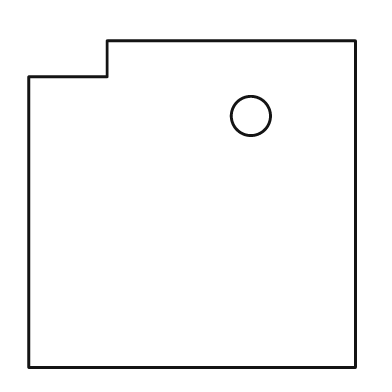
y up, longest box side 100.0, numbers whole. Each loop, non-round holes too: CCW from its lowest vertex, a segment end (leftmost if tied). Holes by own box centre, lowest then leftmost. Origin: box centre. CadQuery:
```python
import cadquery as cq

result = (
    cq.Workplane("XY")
    .moveTo(-50.0, -50.0)
    .lineTo(50.0, -50.0)
    .lineTo(50.0, 50.0)
    .lineTo(-26.0, 50.0)
    .lineTo(-26.0, 39.0)
    .lineTo(-50.0, 39.0)
    .close()
    .moveTo(18.0, 27.0)
    .circle(6.0)
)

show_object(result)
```